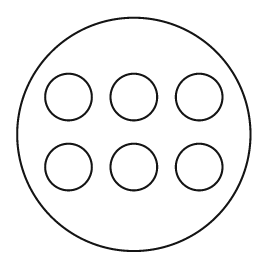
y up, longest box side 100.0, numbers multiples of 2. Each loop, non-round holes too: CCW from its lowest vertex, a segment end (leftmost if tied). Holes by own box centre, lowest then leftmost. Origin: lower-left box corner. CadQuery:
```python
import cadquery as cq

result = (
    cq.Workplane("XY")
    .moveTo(50.0, 50.0)
    .circle(50.0)
    .moveTo(22.0, 36.0)
    .circle(10.0)
    .moveTo(50.0, 36.0)
    .circle(10.0)
    .moveTo(78.0, 36.0)
    .circle(10.0)
    .moveTo(22.0, 66.0)
    .circle(10.0)
    .moveTo(50.0, 66.0)
    .circle(10.0)
    .moveTo(78.0, 66.0)
    .circle(10.0)
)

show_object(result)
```